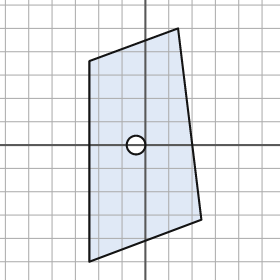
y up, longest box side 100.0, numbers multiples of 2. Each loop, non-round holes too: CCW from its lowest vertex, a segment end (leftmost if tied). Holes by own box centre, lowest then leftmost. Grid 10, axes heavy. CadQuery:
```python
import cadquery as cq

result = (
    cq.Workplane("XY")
    .moveTo(-24.0, -50.0)
    .lineTo(24.0, -32.0)
    .lineTo(14.0, 50.0)
    .lineTo(-24.0, 36.0)
    .close()
    .moveTo(-4.0, 0.0)
    .circle(4.0)
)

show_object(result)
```